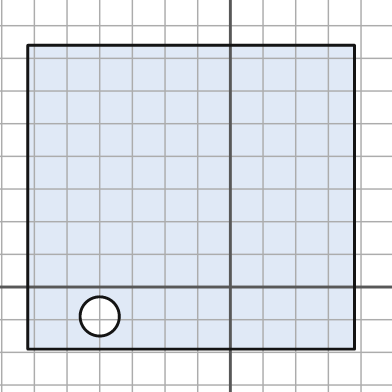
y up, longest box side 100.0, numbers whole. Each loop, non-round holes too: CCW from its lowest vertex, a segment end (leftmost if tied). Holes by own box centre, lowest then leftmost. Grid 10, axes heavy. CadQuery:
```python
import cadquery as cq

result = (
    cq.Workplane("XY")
    .moveTo(-62.0, -19.0)
    .lineTo(38.0, -19.0)
    .lineTo(38.0, 74.0)
    .lineTo(-62.0, 74.0)
    .close()
    .moveTo(-40.0, -9.0)
    .circle(6.0)
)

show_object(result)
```